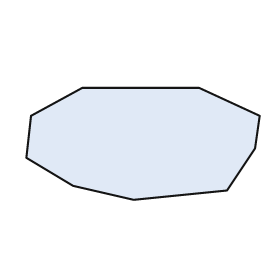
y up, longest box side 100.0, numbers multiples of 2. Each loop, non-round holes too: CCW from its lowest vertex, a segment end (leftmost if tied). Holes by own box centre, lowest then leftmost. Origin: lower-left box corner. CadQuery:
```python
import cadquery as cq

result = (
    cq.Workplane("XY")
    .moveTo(46.0, 0.0)
    .lineTo(86.0, 4.0)
    .lineTo(98.0, 22.0)
    .lineTo(100.0, 36.0)
    .lineTo(74.0, 48.0)
    .lineTo(24.0, 48.0)
    .lineTo(2.0, 36.0)
    .lineTo(0.0, 18.0)
    .lineTo(20.0, 6.0)
    .close()
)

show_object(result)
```